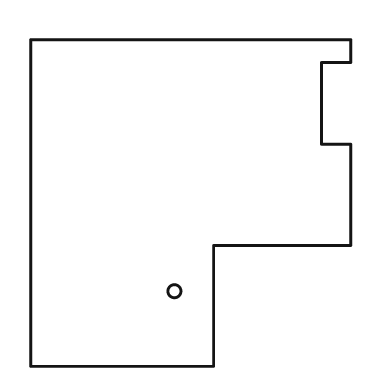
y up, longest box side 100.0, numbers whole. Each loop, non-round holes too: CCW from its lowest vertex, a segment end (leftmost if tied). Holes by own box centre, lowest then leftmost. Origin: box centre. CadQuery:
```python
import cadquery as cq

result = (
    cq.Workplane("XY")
    .moveTo(-49.0, -50.0)
    .lineTo(7.0, -50.0)
    .lineTo(7.0, -13.0)
    .lineTo(49.0, -13.0)
    .lineTo(49.0, 18.0)
    .lineTo(40.0, 18.0)
    .lineTo(40.0, 43.0)
    .lineTo(49.0, 43.0)
    .lineTo(49.0, 50.0)
    .lineTo(-49.0, 50.0)
    .close()
    .moveTo(-5.0, -27.0)
    .circle(2.0)
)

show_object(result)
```